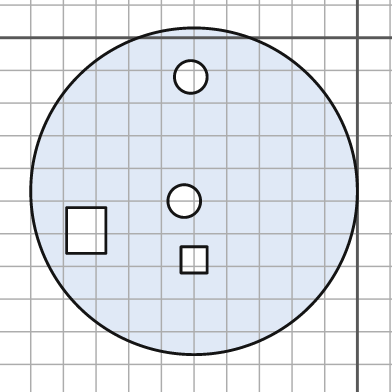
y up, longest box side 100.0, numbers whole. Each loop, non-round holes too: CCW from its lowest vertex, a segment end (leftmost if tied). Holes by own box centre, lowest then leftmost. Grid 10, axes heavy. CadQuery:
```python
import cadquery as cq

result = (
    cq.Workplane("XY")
    .moveTo(-50.0, -47.0)
    .circle(50.0)
    .moveTo(-54.0, -72.0)
    .lineTo(-46.0, -72.0)
    .lineTo(-46.0, -64.0)
    .lineTo(-54.0, -64.0)
    .close()
    .moveTo(-89.0, -66.0)
    .lineTo(-77.0, -66.0)
    .lineTo(-77.0, -52.0)
    .lineTo(-89.0, -52.0)
    .close()
    .moveTo(-53.0, -50.0)
    .circle(5.0)
    .moveTo(-51.0, -12.0)
    .circle(5.0)
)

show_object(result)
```